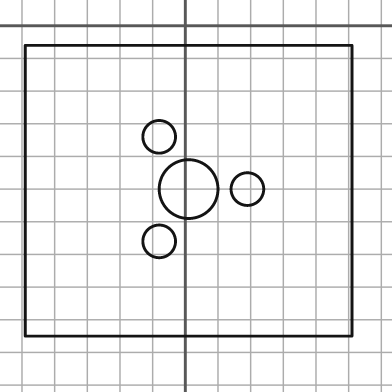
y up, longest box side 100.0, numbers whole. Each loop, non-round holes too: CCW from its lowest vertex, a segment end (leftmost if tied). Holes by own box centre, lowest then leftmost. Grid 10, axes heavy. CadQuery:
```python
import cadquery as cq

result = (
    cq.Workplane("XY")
    .moveTo(-49.0, -95.0)
    .lineTo(51.0, -95.0)
    .lineTo(51.0, -6.0)
    .lineTo(-49.0, -6.0)
    .close()
    .moveTo(-8.0, -66.0)
    .circle(5.0)
    .moveTo(1.0, -50.0)
    .circle(9.0)
    .moveTo(19.0, -50.0)
    .circle(5.0)
    .moveTo(-8.0, -34.0)
    .circle(5.0)
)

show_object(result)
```